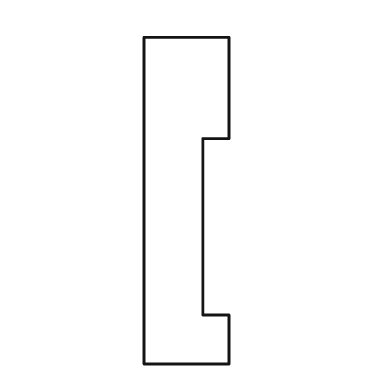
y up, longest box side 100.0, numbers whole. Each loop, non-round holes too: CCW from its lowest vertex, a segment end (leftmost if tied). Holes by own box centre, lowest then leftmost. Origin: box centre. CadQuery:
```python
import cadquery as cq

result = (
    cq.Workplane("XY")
    .moveTo(-13.0, -50.0)
    .lineTo(13.0, -50.0)
    .lineTo(13.0, -35.0)
    .lineTo(5.0, -35.0)
    .lineTo(5.0, 19.0)
    .lineTo(13.0, 19.0)
    .lineTo(13.0, 50.0)
    .lineTo(-13.0, 50.0)
    .close()
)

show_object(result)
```